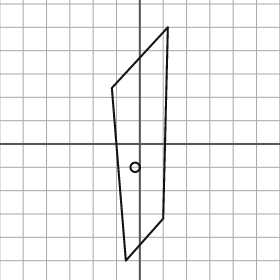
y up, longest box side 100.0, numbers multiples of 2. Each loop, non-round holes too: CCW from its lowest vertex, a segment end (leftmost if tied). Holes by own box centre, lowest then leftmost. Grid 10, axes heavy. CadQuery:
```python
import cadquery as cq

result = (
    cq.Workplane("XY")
    .moveTo(-6.0, -50.0)
    .lineTo(10.0, -32.0)
    .lineTo(12.0, 50.0)
    .lineTo(-12.0, 24.0)
    .close()
    .moveTo(-2.0, -10.0)
    .circle(2.0)
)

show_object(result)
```